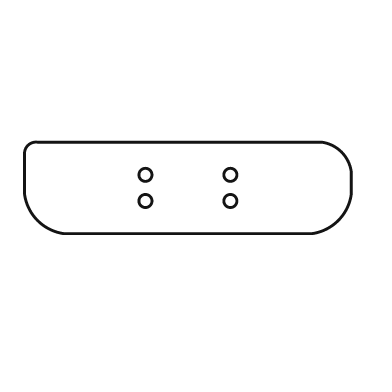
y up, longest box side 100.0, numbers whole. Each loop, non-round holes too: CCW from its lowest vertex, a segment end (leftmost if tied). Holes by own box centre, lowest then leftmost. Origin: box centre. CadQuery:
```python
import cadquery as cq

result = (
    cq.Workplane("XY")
    .moveTo(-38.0, -14.0)
    .lineTo(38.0, -14.0)
    .threePointArc((46.0, -10.0), (50.0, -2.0))
    .lineTo(50.0, 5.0)
    .threePointArc((47.0, 11.0), (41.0, 14.0))
    .lineTo(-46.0, 14.0)
    .threePointArc((-49.0, 13.0), (-50.0, 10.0))
    .lineTo(-50.0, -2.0)
    .threePointArc((-46.0, -10.0), (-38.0, -14.0))
    .close()
    .moveTo(-13.0, -4.0)
    .circle(2.0)
    .moveTo(13.0, -4.0)
    .circle(2.0)
    .moveTo(-13.0, 4.0)
    .circle(2.0)
    .moveTo(13.0, 4.0)
    .circle(2.0)
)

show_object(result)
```